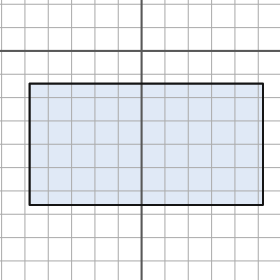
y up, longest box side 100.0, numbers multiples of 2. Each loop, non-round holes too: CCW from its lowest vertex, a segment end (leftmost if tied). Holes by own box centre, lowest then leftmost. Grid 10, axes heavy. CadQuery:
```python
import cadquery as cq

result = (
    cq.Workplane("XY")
    .moveTo(-48.0, -66.0)
    .lineTo(52.0, -66.0)
    .lineTo(52.0, -14.0)
    .lineTo(-48.0, -14.0)
    .close()
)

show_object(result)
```